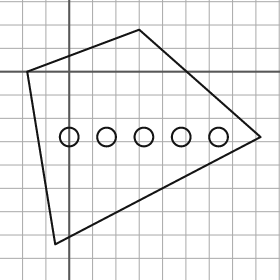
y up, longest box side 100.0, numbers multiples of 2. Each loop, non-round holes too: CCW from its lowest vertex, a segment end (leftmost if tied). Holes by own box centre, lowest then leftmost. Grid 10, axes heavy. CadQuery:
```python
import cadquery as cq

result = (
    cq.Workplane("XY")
    .moveTo(-6.0, -74.0)
    .lineTo(82.0, -28.0)
    .lineTo(30.0, 18.0)
    .lineTo(-18.0, 0.0)
    .close()
    .moveTo(0.0, -28.0)
    .circle(4.0)
    .moveTo(16.0, -28.0)
    .circle(4.0)
    .moveTo(32.0, -28.0)
    .circle(4.0)
    .moveTo(48.0, -28.0)
    .circle(4.0)
    .moveTo(64.0, -28.0)
    .circle(4.0)
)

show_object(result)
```